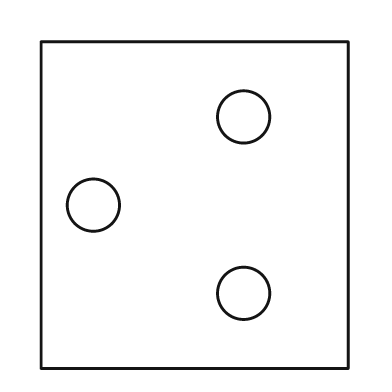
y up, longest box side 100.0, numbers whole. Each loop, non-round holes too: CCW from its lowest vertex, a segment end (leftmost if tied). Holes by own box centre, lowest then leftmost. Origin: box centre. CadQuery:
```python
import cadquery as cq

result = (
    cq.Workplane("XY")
    .moveTo(-47.0, -50.0)
    .lineTo(47.0, -50.0)
    .lineTo(47.0, 50.0)
    .lineTo(-47.0, 50.0)
    .close()
    .moveTo(15.0, -27.0)
    .circle(8.0)
    .moveTo(-31.0, 0.0)
    .circle(8.0)
    .moveTo(15.0, 27.0)
    .circle(8.0)
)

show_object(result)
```